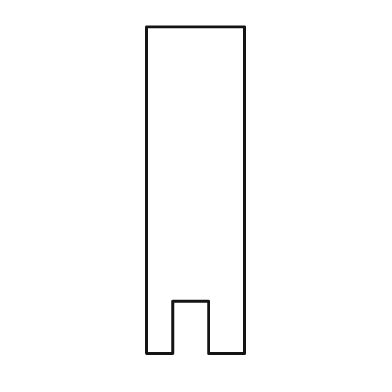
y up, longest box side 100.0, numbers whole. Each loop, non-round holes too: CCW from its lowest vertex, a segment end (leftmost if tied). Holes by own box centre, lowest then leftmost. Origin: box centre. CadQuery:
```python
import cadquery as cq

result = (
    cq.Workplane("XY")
    .moveTo(-15.0, -50.0)
    .lineTo(-7.0, -50.0)
    .lineTo(-7.0, -34.0)
    .lineTo(4.0, -34.0)
    .lineTo(4.0, -50.0)
    .lineTo(15.0, -50.0)
    .lineTo(15.0, 50.0)
    .lineTo(-15.0, 50.0)
    .close()
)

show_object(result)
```